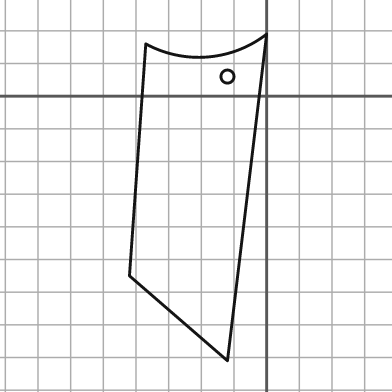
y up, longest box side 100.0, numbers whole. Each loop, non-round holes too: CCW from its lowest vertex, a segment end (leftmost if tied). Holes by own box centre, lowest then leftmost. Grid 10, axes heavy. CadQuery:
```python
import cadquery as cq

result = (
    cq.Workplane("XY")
    .moveTo(-12.0, -81.0)
    .lineTo(0.0, 19.0)
    .threePointArc((-18.0, 12.0), (-37.0, 16.0))
    .lineTo(-42.0, -55.0)
    .close()
    .moveTo(-12.0, 6.0)
    .circle(2.0)
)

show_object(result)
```